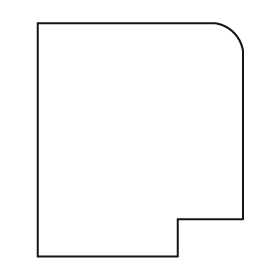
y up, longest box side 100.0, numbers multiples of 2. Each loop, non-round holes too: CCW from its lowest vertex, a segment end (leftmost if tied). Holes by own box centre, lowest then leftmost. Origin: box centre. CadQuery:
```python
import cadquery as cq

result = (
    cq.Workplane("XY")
    .moveTo(-44.0, -50.0)
    .lineTo(16.0, -50.0)
    .lineTo(16.0, -34.0)
    .lineTo(44.0, -34.0)
    .lineTo(44.0, 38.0)
    .threePointArc((40.0, 46.0), (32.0, 50.0))
    .lineTo(-44.0, 50.0)
    .close()
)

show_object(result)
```